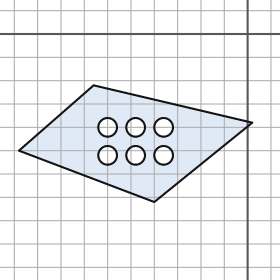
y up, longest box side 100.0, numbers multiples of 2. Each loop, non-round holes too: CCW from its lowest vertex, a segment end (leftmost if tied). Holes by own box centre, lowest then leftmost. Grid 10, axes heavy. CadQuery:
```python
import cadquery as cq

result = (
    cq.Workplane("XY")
    .moveTo(-40.0, -72.0)
    .lineTo(2.0, -38.0)
    .lineTo(-66.0, -22.0)
    .lineTo(-98.0, -50.0)
    .close()
    .moveTo(-60.0, -52.0)
    .circle(4.0)
    .moveTo(-48.0, -52.0)
    .circle(4.0)
    .moveTo(-36.0, -52.0)
    .circle(4.0)
    .moveTo(-60.0, -40.0)
    .circle(4.0)
    .moveTo(-48.0, -40.0)
    .circle(4.0)
    .moveTo(-36.0, -40.0)
    .circle(4.0)
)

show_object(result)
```